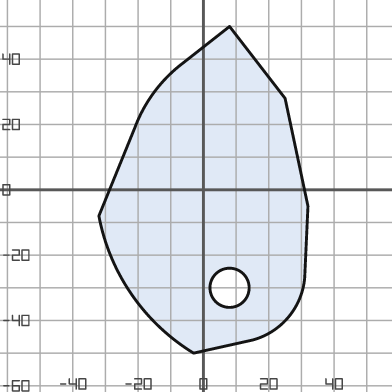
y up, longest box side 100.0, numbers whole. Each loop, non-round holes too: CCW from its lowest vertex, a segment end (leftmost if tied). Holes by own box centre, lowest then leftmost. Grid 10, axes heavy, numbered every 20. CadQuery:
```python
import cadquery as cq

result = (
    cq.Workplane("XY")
    .moveTo(-3.0, -50.0)
    .lineTo(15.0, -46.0)
    .threePointArc((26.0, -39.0), (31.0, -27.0))
    .lineTo(32.0, -5.0)
    .lineTo(25.0, 28.0)
    .lineTo(8.0, 50.0)
    .lineTo(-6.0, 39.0)
    .threePointArc((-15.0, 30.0), (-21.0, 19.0))
    .lineTo(-32.0, -8.0)
    .threePointArc((-22.0, -32.0), (-3.0, -50.0))
    .close()
    .moveTo(8.0, -30.0)
    .circle(6.0)
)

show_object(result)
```